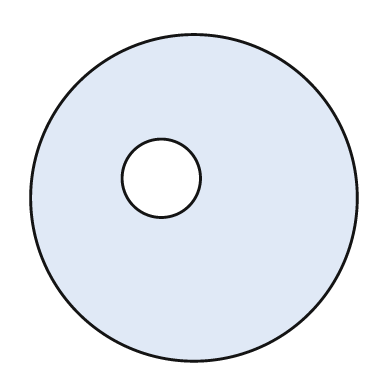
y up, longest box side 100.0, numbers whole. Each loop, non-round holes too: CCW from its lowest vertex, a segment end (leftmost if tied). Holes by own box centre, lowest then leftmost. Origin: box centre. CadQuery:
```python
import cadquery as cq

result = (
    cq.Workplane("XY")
    .moveTo(0.0, 0.0)
    .circle(50.0)
    .moveTo(-10.0, 6.0)
    .circle(12.0)
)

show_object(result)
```